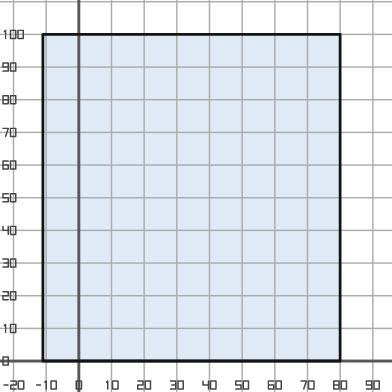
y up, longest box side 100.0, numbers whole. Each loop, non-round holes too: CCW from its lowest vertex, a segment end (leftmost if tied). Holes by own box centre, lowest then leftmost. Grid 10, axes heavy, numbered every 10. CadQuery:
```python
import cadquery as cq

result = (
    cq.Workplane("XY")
    .moveTo(-11.0, 0.0)
    .lineTo(80.0, 0.0)
    .lineTo(80.0, 100.0)
    .lineTo(-11.0, 100.0)
    .close()
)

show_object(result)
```